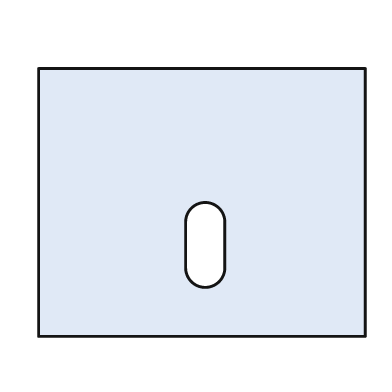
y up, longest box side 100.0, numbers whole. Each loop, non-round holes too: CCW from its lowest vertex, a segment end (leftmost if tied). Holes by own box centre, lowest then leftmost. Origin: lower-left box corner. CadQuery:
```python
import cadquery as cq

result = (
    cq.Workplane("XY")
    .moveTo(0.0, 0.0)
    .lineTo(100.0, 0.0)
    .lineTo(100.0, 82.0)
    .lineTo(0.0, 82.0)
    .close()
    .moveTo(45.0, 21.0)
    .threePointArc((51.0, 15.0), (57.0, 21.0))
    .lineTo(57.0, 35.0)
    .threePointArc((51.0, 41.0), (45.0, 35.0))
    .close()
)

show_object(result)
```